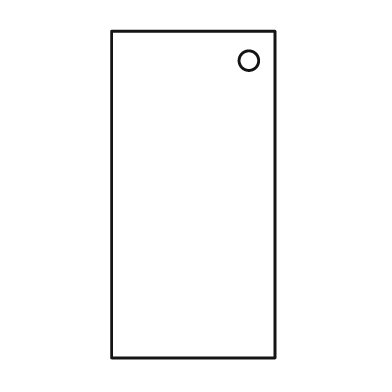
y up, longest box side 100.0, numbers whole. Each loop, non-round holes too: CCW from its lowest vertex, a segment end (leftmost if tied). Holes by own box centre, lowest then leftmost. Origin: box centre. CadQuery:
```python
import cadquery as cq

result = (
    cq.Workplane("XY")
    .moveTo(-25.0, -50.0)
    .lineTo(25.0, -50.0)
    .lineTo(25.0, 50.0)
    .lineTo(-25.0, 50.0)
    .close()
    .moveTo(17.0, 41.0)
    .circle(3.0)
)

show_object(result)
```